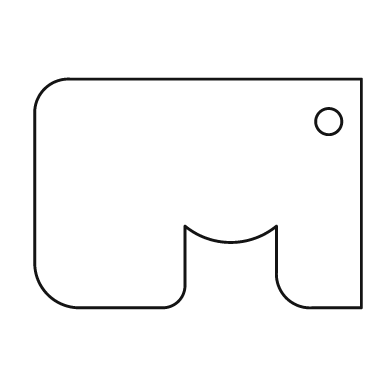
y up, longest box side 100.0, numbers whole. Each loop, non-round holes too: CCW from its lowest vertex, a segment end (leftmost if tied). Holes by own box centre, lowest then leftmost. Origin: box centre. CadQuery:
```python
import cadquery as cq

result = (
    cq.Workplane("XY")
    .moveTo(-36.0, -35.0)
    .lineTo(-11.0, -35.0)
    .threePointArc((-6.0, -33.0), (-4.0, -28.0))
    .lineTo(-4.0, -10.0)
    .threePointArc((10.0, -15.0), (24.0, -10.0))
    .lineTo(24.0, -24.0)
    .threePointArc((27.0, -32.0), (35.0, -35.0))
    .lineTo(50.0, -35.0)
    .lineTo(50.0, 35.0)
    .lineTo(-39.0, 35.0)
    .threePointArc((-47.0, 32.0), (-50.0, 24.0))
    .lineTo(-50.0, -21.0)
    .threePointArc((-46.0, -31.0), (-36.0, -35.0))
    .close()
    .moveTo(40.0, 22.0)
    .circle(4.0)
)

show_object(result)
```